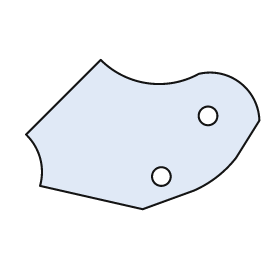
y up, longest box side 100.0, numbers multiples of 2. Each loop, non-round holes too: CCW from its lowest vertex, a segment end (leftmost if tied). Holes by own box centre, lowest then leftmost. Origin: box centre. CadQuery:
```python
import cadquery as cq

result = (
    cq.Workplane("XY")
    .moveTo(0.0, -32.0)
    .lineTo(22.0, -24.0)
    .threePointArc((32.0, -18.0), (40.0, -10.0))
    .lineTo(50.0, 6.0)
    .threePointArc((42.0, 22.0), (24.0, 26.0))
    .threePointArc((2.0, 22.0), (-18.0, 32.0))
    .lineTo(-50.0, 0.0)
    .threePointArc((-44.0, -10.0), (-44.0, -22.0))
    .close()
    .moveTo(8.0, -18.0)
    .circle(4.0)
    .moveTo(28.0, 8.0)
    .circle(4.0)
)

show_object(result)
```